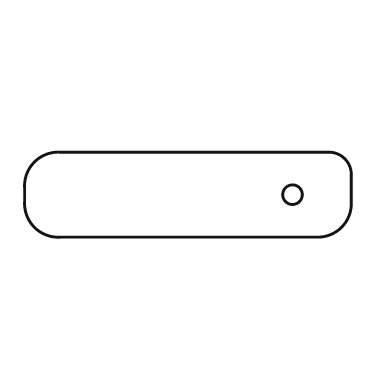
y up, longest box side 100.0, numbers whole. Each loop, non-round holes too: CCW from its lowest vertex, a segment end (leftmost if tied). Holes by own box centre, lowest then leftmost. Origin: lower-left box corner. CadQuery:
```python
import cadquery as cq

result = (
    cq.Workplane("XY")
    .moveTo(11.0, 0.0)
    .lineTo(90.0, 0.0)
    .threePointArc((97.0, 3.0), (100.0, 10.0))
    .lineTo(100.0, 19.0)
    .threePointArc((98.0, 24.0), (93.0, 26.0))
    .lineTo(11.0, 26.0)
    .threePointArc((3.0, 23.0), (0.0, 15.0))
    .lineTo(0.0, 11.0)
    .threePointArc((3.0, 3.0), (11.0, 0.0))
    .close()
    .moveTo(82.0, 13.0)
    .circle(3.0)
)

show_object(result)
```